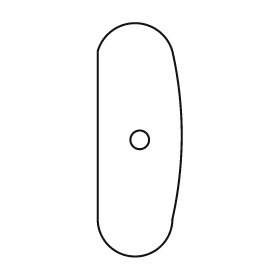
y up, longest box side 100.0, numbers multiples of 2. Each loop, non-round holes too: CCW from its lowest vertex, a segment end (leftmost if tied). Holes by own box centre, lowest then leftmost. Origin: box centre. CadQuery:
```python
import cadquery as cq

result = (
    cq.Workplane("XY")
    .moveTo(-18.0, -34.0)
    .threePointArc((-2.0, -50.0), (14.0, -34.0))
    .threePointArc((18.0, 2.0), (14.0, 38.0))
    .threePointArc((-2.0, 50.0), (-18.0, 38.0))
    .close()
    .moveTo(0.0, 0.0)
    .circle(4.0)
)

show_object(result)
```